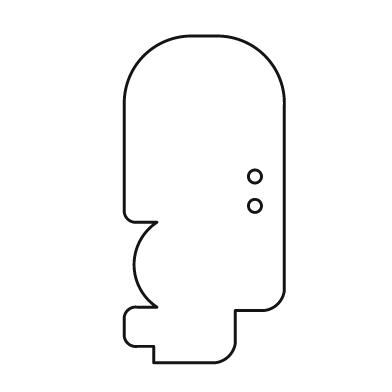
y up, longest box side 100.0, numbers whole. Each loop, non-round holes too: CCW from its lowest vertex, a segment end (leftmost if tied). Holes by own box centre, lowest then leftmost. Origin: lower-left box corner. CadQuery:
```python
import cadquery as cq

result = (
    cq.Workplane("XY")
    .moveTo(9.0, 0.0)
    .lineTo(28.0, 0.0)
    .threePointArc((32.0, 2.0), (34.0, 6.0))
    .lineTo(34.0, 16.0)
    .lineTo(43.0, 16.0)
    .threePointArc((47.0, 18.0), (49.0, 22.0))
    .lineTo(49.0, 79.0)
    .threePointArc((43.0, 94.0), (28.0, 100.0))
    .lineTo(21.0, 100.0)
    .threePointArc((6.0, 94.0), (0.0, 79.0))
    .lineTo(0.0, 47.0)
    .threePointArc((1.0, 44.0), (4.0, 43.0))
    .lineTo(10.0, 43.0)
    .threePointArc((3.0, 30.0), (10.0, 17.0))
    .lineTo(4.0, 17.0)
    .threePointArc((1.0, 16.0), (0.0, 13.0))
    .lineTo(0.0, 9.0)
    .threePointArc((1.0, 6.0), (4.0, 5.0))
    .lineTo(9.0, 5.0)
    .close()
    .moveTo(40.0, 48.0)
    .circle(2.0)
    .moveTo(40.0, 57.0)
    .circle(2.0)
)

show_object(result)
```